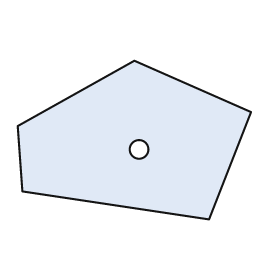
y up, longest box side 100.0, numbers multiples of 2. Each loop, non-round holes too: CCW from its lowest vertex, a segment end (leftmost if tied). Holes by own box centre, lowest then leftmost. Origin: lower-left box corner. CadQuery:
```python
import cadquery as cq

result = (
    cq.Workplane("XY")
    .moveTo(82.0, 0.0)
    .lineTo(100.0, 46.0)
    .lineTo(50.0, 68.0)
    .lineTo(0.0, 40.0)
    .lineTo(2.0, 12.0)
    .close()
    .moveTo(52.0, 30.0)
    .circle(4.0)
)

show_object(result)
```